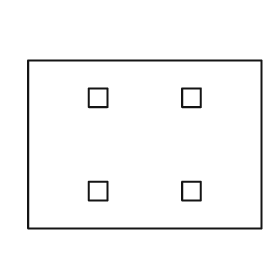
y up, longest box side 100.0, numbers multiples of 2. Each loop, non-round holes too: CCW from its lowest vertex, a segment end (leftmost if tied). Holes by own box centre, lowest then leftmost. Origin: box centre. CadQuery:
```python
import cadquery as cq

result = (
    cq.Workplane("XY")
    .moveTo(-50.0, -36.0)
    .lineTo(50.0, -36.0)
    .lineTo(50.0, 36.0)
    .lineTo(-50.0, 36.0)
    .close()
    .moveTo(-24.0, -24.0)
    .lineTo(-16.0, -24.0)
    .lineTo(-16.0, -16.0)
    .lineTo(-24.0, -16.0)
    .close()
    .moveTo(16.0, -24.0)
    .lineTo(24.0, -24.0)
    .lineTo(24.0, -16.0)
    .lineTo(16.0, -16.0)
    .close()
    .moveTo(-24.0, 16.0)
    .lineTo(-16.0, 16.0)
    .lineTo(-16.0, 24.0)
    .lineTo(-24.0, 24.0)
    .close()
    .moveTo(16.0, 16.0)
    .lineTo(24.0, 16.0)
    .lineTo(24.0, 24.0)
    .lineTo(16.0, 24.0)
    .close()
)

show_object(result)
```